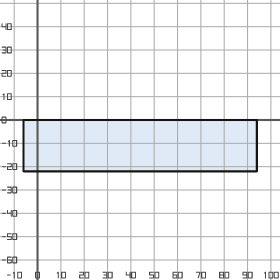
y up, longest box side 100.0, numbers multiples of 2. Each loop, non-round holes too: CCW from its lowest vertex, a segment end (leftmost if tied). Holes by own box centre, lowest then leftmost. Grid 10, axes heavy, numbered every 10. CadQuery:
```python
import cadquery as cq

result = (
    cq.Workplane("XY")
    .moveTo(-6.0, -22.0)
    .lineTo(94.0, -22.0)
    .lineTo(94.0, 0.0)
    .lineTo(-6.0, 0.0)
    .close()
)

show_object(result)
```